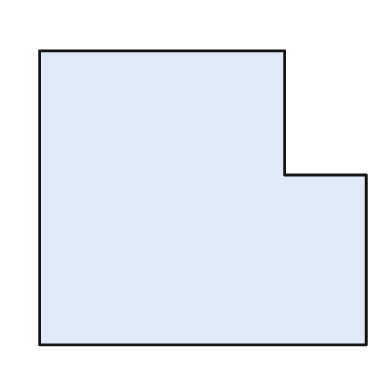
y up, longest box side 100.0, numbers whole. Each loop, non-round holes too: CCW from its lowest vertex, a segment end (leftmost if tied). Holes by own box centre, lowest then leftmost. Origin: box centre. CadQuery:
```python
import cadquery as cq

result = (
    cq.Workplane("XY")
    .moveTo(-50.0, -45.0)
    .lineTo(50.0, -45.0)
    .lineTo(50.0, 7.0)
    .lineTo(25.0, 7.0)
    .lineTo(25.0, 45.0)
    .lineTo(-50.0, 45.0)
    .close()
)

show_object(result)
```